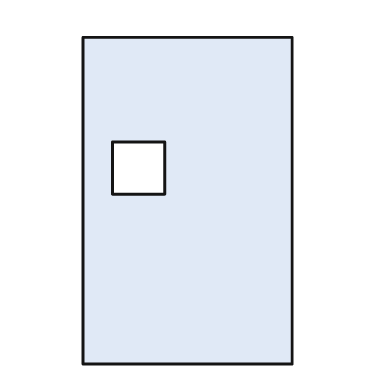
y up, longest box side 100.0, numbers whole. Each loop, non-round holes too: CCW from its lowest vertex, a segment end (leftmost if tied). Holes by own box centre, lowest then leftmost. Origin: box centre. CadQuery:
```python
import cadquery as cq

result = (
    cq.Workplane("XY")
    .moveTo(-32.0, -50.0)
    .lineTo(32.0, -50.0)
    .lineTo(32.0, 50.0)
    .lineTo(-32.0, 50.0)
    .close()
    .moveTo(-23.0, 2.0)
    .lineTo(-7.0, 2.0)
    .lineTo(-7.0, 18.0)
    .lineTo(-23.0, 18.0)
    .close()
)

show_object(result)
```